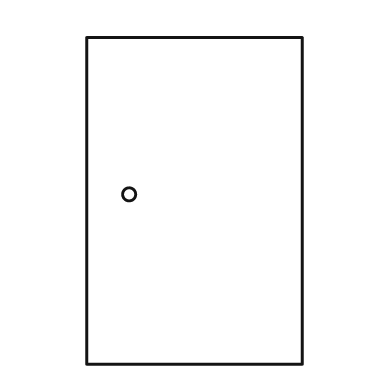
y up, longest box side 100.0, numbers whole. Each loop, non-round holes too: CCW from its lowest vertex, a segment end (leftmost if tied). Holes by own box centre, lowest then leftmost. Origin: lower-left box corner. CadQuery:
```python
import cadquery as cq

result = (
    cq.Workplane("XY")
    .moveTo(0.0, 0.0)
    .lineTo(66.0, 0.0)
    .lineTo(66.0, 100.0)
    .lineTo(0.0, 100.0)
    .close()
    .moveTo(13.0, 52.0)
    .circle(2.0)
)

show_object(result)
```